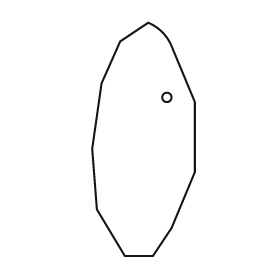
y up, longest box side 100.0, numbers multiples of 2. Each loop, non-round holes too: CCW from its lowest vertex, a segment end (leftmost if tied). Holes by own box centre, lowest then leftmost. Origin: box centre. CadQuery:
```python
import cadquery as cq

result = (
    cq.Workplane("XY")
    .moveTo(-8.0, -50.0)
    .lineTo(4.0, -50.0)
    .lineTo(12.0, -38.0)
    .lineTo(22.0, -14.0)
    .lineTo(22.0, 16.0)
    .lineTo(12.0, 40.0)
    .threePointArc((8.0, 46.0), (2.0, 50.0))
    .lineTo(-10.0, 42.0)
    .lineTo(-18.0, 24.0)
    .lineTo(-22.0, -4.0)
    .lineTo(-20.0, -30.0)
    .close()
    .moveTo(10.0, 18.0)
    .circle(2.0)
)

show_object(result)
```